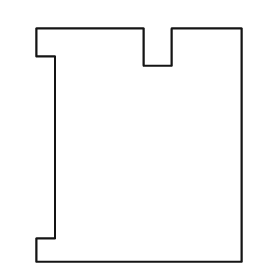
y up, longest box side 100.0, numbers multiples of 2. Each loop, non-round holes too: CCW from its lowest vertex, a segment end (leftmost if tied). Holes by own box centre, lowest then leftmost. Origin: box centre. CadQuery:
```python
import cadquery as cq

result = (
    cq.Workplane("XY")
    .moveTo(-44.0, -50.0)
    .lineTo(44.0, -50.0)
    .lineTo(44.0, 50.0)
    .lineTo(14.0, 50.0)
    .lineTo(14.0, 34.0)
    .lineTo(2.0, 34.0)
    .lineTo(2.0, 50.0)
    .lineTo(-44.0, 50.0)
    .lineTo(-44.0, 38.0)
    .lineTo(-36.0, 38.0)
    .lineTo(-36.0, -40.0)
    .lineTo(-44.0, -40.0)
    .close()
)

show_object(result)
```